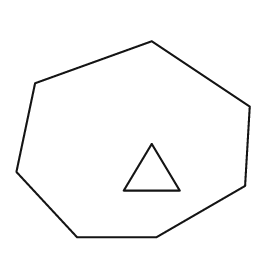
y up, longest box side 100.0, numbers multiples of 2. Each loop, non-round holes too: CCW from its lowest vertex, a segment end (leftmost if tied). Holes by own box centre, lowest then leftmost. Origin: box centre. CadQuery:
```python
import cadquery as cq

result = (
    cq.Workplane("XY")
    .moveTo(-24.0, -42.0)
    .lineTo(10.0, -42.0)
    .lineTo(48.0, -20.0)
    .lineTo(50.0, 14.0)
    .lineTo(8.0, 42.0)
    .lineTo(-42.0, 24.0)
    .lineTo(-50.0, -14.0)
    .close()
    .moveTo(-4.0, -22.0)
    .lineTo(20.0, -22.0)
    .lineTo(8.0, -2.0)
    .close()
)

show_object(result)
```